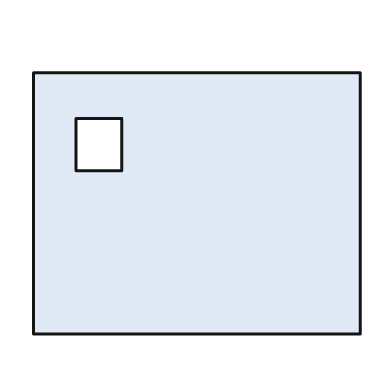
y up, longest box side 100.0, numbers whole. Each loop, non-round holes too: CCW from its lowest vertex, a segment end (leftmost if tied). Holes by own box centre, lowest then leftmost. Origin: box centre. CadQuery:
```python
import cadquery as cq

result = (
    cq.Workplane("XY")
    .moveTo(-50.0, -40.0)
    .lineTo(50.0, -40.0)
    .lineTo(50.0, 40.0)
    .lineTo(-50.0, 40.0)
    .close()
    .moveTo(-37.0, 10.0)
    .lineTo(-23.0, 10.0)
    .lineTo(-23.0, 26.0)
    .lineTo(-37.0, 26.0)
    .close()
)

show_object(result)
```